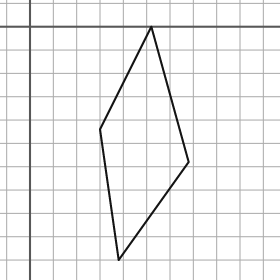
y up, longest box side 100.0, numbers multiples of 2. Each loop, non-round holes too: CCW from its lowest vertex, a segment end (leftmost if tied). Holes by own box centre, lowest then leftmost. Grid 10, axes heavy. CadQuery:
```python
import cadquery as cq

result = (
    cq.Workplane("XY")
    .moveTo(38.0, -100.0)
    .lineTo(68.0, -58.0)
    .lineTo(52.0, 0.0)
    .lineTo(30.0, -44.0)
    .close()
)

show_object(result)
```